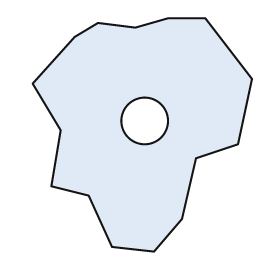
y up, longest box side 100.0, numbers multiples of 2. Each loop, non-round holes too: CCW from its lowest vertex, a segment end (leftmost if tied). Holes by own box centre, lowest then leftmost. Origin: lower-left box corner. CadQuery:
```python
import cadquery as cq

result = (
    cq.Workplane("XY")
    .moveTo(52.0, 0.0)
    .lineTo(64.0, 14.0)
    .lineTo(70.0, 40.0)
    .lineTo(88.0, 46.0)
    .lineTo(94.0, 74.0)
    .lineTo(74.0, 100.0)
    .lineTo(58.0, 100.0)
    .lineTo(44.0, 96.0)
    .lineTo(28.0, 98.0)
    .lineTo(18.0, 92.0)
    .lineTo(0.0, 72.0)
    .lineTo(12.0, 52.0)
    .lineTo(8.0, 28.0)
    .lineTo(24.0, 24.0)
    .lineTo(34.0, 2.0)
    .close()
    .moveTo(48.0, 56.0)
    .circle(10.0)
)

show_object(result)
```